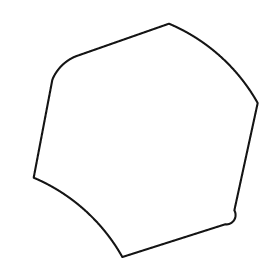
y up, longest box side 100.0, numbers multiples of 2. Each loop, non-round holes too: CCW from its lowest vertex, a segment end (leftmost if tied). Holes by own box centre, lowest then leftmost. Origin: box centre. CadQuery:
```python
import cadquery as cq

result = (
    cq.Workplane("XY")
    .moveTo(-10.0, -50.0)
    .lineTo(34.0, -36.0)
    .threePointArc((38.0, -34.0), (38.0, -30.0))
    .lineTo(48.0, 16.0)
    .threePointArc((32.0, 36.0), (10.0, 50.0))
    .lineTo(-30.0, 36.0)
    .threePointArc((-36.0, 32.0), (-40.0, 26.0))
    .lineTo(-48.0, -16.0)
    .threePointArc((-26.0, -30.0), (-10.0, -50.0))
    .close()
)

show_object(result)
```